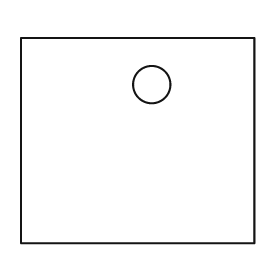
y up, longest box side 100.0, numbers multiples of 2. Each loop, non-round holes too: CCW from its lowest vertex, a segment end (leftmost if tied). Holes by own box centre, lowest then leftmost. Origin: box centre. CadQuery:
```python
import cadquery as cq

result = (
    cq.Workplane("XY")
    .moveTo(-50.0, -44.0)
    .lineTo(50.0, -44.0)
    .lineTo(50.0, 44.0)
    .lineTo(-50.0, 44.0)
    .close()
    .moveTo(6.0, 24.0)
    .circle(8.0)
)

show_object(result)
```